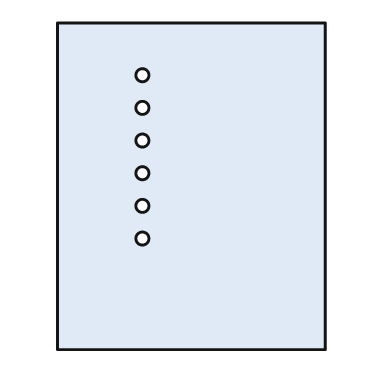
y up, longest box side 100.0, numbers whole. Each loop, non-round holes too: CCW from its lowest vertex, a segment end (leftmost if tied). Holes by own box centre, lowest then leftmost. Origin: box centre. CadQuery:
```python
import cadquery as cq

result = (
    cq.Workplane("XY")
    .moveTo(-41.0, -50.0)
    .lineTo(41.0, -50.0)
    .lineTo(41.0, 50.0)
    .lineTo(-41.0, 50.0)
    .close()
    .moveTo(-15.0, -16.0)
    .circle(2.0)
    .moveTo(-15.0, -6.0)
    .circle(2.0)
    .moveTo(-15.0, 4.0)
    .circle(2.0)
    .moveTo(-15.0, 14.0)
    .circle(2.0)
    .moveTo(-15.0, 24.0)
    .circle(2.0)
    .moveTo(-15.0, 34.0)
    .circle(2.0)
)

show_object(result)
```